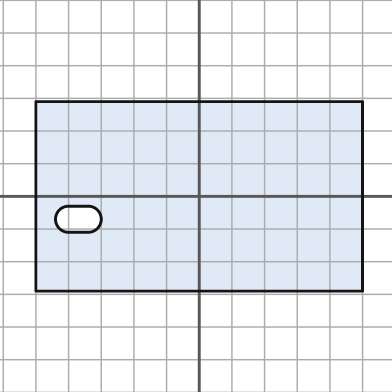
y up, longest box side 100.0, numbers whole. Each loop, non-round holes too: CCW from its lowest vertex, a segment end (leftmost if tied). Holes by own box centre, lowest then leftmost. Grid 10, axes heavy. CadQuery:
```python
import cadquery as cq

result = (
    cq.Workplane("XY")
    .moveTo(-50.0, -29.0)
    .lineTo(50.0, -29.0)
    .lineTo(50.0, 29.0)
    .lineTo(-50.0, 29.0)
    .close()
    .moveTo(-40.0, -11.0)
    .lineTo(-34.0, -11.0)
    .threePointArc((-30.0, -7.0), (-34.0, -3.0))
    .lineTo(-40.0, -3.0)
    .threePointArc((-44.0, -7.0), (-40.0, -11.0))
    .close()
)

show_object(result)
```